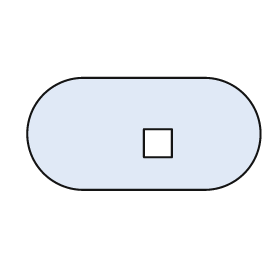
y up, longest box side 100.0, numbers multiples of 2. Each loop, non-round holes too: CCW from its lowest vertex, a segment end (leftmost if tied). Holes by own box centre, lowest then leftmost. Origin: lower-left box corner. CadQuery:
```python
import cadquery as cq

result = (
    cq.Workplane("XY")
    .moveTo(24.0, 0.0)
    .lineTo(76.0, 0.0)
    .threePointArc((100.0, 24.0), (76.0, 48.0))
    .lineTo(24.0, 48.0)
    .threePointArc((0.0, 24.0), (24.0, 0.0))
    .close()
    .moveTo(50.0, 14.0)
    .lineTo(62.0, 14.0)
    .lineTo(62.0, 26.0)
    .lineTo(50.0, 26.0)
    .close()
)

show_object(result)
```